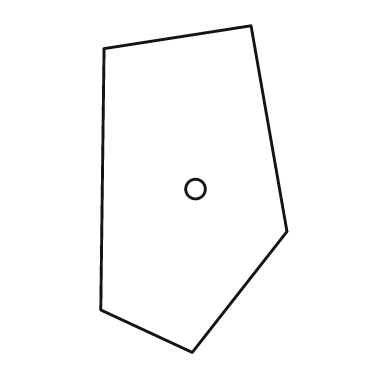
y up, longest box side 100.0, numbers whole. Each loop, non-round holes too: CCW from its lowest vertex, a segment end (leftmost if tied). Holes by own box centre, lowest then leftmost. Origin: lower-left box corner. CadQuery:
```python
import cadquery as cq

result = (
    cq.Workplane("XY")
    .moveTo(28.0, 0.0)
    .lineTo(57.0, 37.0)
    .lineTo(46.0, 100.0)
    .lineTo(1.0, 93.0)
    .lineTo(0.0, 13.0)
    .close()
    .moveTo(29.0, 50.0)
    .circle(3.0)
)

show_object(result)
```